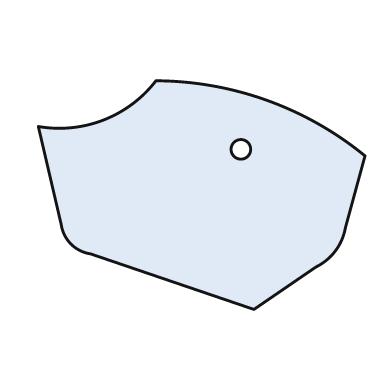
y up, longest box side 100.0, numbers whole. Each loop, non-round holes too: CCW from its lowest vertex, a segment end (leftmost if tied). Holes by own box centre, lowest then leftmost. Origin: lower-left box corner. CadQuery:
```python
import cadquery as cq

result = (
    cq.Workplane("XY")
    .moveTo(66.0, 0.0)
    .lineTo(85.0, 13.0)
    .threePointArc((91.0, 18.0), (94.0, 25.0))
    .lineTo(100.0, 47.0)
    .threePointArc((70.0, 64.0), (36.0, 70.0))
    .threePointArc((20.0, 58.0), (0.0, 56.0))
    .lineTo(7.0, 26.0)
    .threePointArc((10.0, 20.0), (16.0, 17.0))
    .close()
    .moveTo(62.0, 49.0)
    .circle(3.0)
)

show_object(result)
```